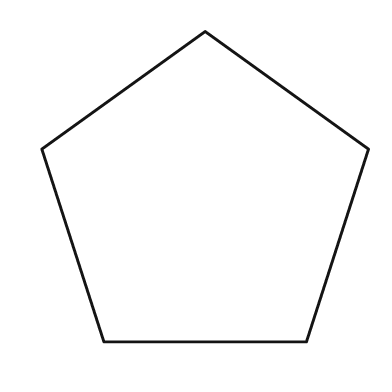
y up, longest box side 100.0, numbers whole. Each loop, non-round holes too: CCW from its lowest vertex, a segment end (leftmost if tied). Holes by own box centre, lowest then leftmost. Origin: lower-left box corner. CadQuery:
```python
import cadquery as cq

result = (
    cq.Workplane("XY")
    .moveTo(19.0, 0.0)
    .lineTo(81.0, 0.0)
    .lineTo(100.0, 59.0)
    .lineTo(50.0, 95.0)
    .lineTo(0.0, 59.0)
    .close()
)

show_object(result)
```